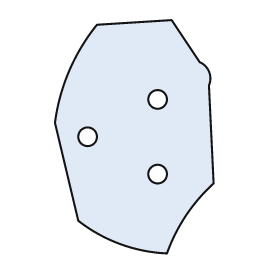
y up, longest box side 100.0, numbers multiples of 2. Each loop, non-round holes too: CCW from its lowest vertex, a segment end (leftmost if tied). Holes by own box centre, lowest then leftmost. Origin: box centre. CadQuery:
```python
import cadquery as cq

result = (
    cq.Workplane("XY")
    .moveTo(14.0, -50.0)
    .threePointArc((22.0, -34.0), (34.0, -20.0))
    .lineTo(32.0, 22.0)
    .threePointArc((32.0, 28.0), (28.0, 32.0))
    .lineTo(16.0, 50.0)
    .lineTo(-16.0, 48.0)
    .threePointArc((-28.0, 28.0), (-34.0, 6.0))
    .lineTo(-24.0, -36.0)
    .threePointArc((-6.0, -46.0), (14.0, -50.0))
    .close()
    .moveTo(10.0, -16.0)
    .circle(4.0)
    .moveTo(-20.0, 0.0)
    .circle(4.0)
    .moveTo(10.0, 16.0)
    .circle(4.0)
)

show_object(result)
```